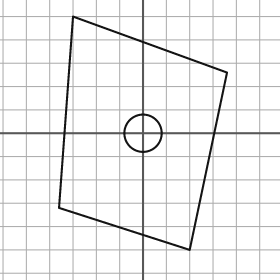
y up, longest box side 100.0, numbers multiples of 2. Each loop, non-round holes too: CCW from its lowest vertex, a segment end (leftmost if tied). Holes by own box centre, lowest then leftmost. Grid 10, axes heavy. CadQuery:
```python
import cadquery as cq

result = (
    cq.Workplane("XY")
    .moveTo(20.0, -50.0)
    .lineTo(36.0, 26.0)
    .lineTo(-30.0, 50.0)
    .lineTo(-36.0, -32.0)
    .close()
    .moveTo(0.0, 0.0)
    .circle(8.0)
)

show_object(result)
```